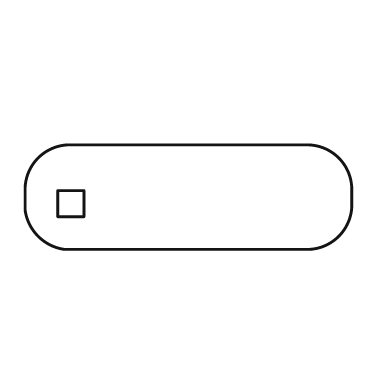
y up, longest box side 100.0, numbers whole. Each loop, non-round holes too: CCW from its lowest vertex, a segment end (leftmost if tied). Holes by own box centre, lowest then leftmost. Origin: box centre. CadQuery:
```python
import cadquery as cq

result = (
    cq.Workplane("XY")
    .moveTo(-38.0, -16.0)
    .lineTo(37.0, -16.0)
    .threePointArc((46.0, -12.0), (50.0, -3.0))
    .lineTo(50.0, 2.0)
    .threePointArc((46.0, 12.0), (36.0, 16.0))
    .lineTo(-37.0, 16.0)
    .threePointArc((-46.0, 12.0), (-50.0, 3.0))
    .lineTo(-50.0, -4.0)
    .threePointArc((-46.0, -12.0), (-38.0, -16.0))
    .close()
    .moveTo(-40.0, -6.0)
    .lineTo(-32.0, -6.0)
    .lineTo(-32.0, 2.0)
    .lineTo(-40.0, 2.0)
    .close()
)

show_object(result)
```